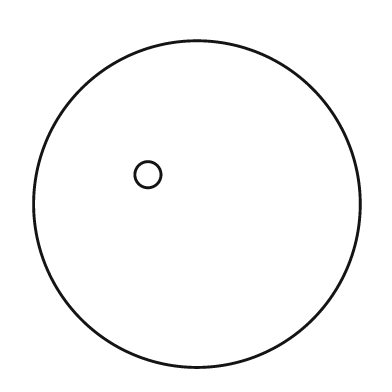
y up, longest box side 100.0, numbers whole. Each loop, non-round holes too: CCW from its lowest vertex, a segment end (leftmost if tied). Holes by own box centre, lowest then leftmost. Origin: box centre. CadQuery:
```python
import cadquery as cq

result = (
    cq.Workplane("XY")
    .moveTo(0.0, 0.0)
    .circle(50.0)
    .moveTo(-15.0, 9.0)
    .circle(4.0)
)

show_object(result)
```